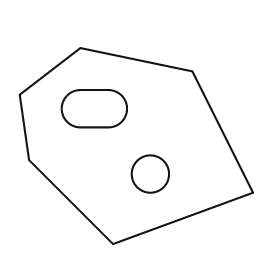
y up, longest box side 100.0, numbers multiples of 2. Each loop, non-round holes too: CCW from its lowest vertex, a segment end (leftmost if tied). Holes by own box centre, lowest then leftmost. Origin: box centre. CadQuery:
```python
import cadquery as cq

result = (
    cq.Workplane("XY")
    .moveTo(-10.0, -42.0)
    .lineTo(50.0, -20.0)
    .lineTo(24.0, 32.0)
    .lineTo(-24.0, 42.0)
    .lineTo(-50.0, 22.0)
    .lineTo(-46.0, -6.0)
    .close()
    .moveTo(6.0, -12.0)
    .circle(8.0)
    .moveTo(-24.0, 8.0)
    .lineTo(-12.0, 8.0)
    .threePointArc((-4.0, 16.0), (-12.0, 24.0))
    .lineTo(-24.0, 24.0)
    .threePointArc((-32.0, 16.0), (-24.0, 8.0))
    .close()
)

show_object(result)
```